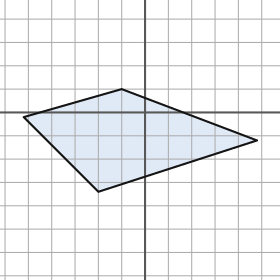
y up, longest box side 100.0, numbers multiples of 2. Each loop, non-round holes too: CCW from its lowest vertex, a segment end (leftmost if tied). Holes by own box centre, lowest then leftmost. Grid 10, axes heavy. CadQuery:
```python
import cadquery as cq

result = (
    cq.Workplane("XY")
    .moveTo(-20.0, -34.0)
    .lineTo(48.0, -12.0)
    .lineTo(-10.0, 10.0)
    .lineTo(-52.0, -2.0)
    .close()
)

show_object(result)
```